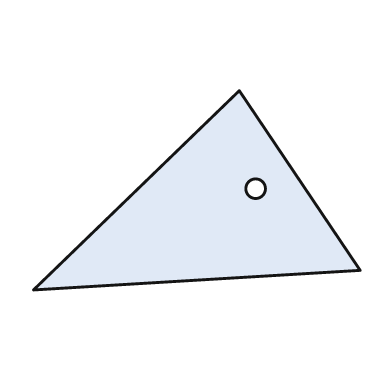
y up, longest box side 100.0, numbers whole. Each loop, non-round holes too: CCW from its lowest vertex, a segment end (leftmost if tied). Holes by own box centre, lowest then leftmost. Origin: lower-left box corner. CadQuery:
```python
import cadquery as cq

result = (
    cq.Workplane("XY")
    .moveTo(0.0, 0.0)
    .lineTo(100.0, 6.0)
    .lineTo(63.0, 61.0)
    .close()
    .moveTo(68.0, 31.0)
    .circle(3.0)
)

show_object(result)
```